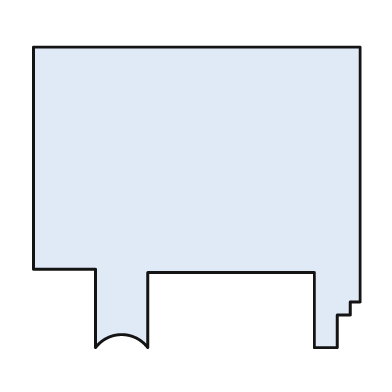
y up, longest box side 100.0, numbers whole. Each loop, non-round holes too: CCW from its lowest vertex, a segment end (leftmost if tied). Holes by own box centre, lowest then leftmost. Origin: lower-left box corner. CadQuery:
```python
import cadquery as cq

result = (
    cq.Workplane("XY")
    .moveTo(19.0, 0.0)
    .threePointArc((27.0, 4.0), (35.0, 0.0))
    .lineTo(35.0, 23.0)
    .lineTo(86.0, 23.0)
    .lineTo(86.0, 0.0)
    .lineTo(93.0, 0.0)
    .lineTo(93.0, 10.0)
    .lineTo(97.0, 10.0)
    .lineTo(97.0, 14.0)
    .lineTo(100.0, 14.0)
    .lineTo(100.0, 92.0)
    .lineTo(0.0, 92.0)
    .lineTo(0.0, 24.0)
    .lineTo(19.0, 24.0)
    .close()
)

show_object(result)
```